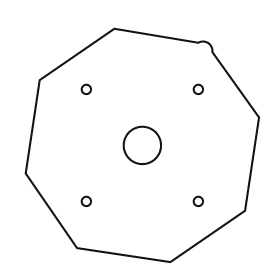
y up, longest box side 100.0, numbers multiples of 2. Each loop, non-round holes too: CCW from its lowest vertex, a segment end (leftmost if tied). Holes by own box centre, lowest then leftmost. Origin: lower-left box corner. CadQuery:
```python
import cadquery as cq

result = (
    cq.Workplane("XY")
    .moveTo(62.0, 0.0)
    .lineTo(94.0, 22.0)
    .lineTo(100.0, 62.0)
    .lineTo(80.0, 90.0)
    .threePointArc((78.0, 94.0), (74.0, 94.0))
    .lineTo(38.0, 100.0)
    .lineTo(6.0, 78.0)
    .lineTo(0.0, 38.0)
    .lineTo(22.0, 6.0)
    .close()
    .moveTo(26.0, 26.0)
    .circle(2.0)
    .moveTo(74.0, 26.0)
    .circle(2.0)
    .moveTo(50.0, 50.0)
    .circle(8.0)
    .moveTo(26.0, 74.0)
    .circle(2.0)
    .moveTo(74.0, 74.0)
    .circle(2.0)
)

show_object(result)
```